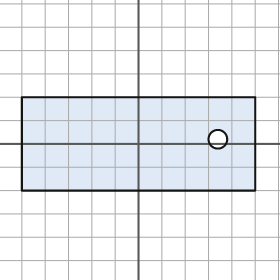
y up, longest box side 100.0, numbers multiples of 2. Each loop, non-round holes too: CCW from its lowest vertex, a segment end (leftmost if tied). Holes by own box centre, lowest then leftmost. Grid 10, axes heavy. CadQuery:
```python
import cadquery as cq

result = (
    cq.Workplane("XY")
    .moveTo(-50.0, -20.0)
    .lineTo(50.0, -20.0)
    .lineTo(50.0, 20.0)
    .lineTo(-50.0, 20.0)
    .close()
    .moveTo(34.0, 2.0)
    .circle(4.0)
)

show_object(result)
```